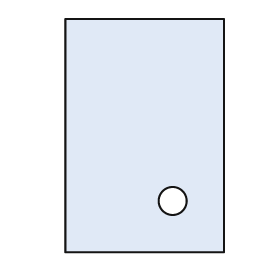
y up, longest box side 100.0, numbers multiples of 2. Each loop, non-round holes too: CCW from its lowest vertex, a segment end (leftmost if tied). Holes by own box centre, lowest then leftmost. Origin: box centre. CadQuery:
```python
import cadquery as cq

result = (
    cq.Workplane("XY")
    .moveTo(-34.0, -50.0)
    .lineTo(34.0, -50.0)
    .lineTo(34.0, 50.0)
    .lineTo(-34.0, 50.0)
    .close()
    .moveTo(12.0, -28.0)
    .circle(6.0)
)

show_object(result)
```